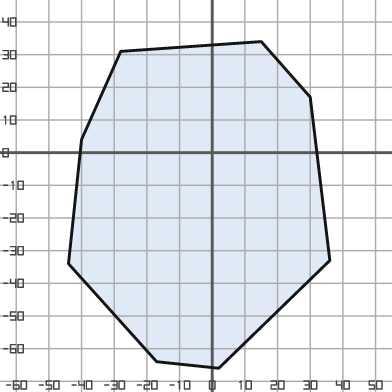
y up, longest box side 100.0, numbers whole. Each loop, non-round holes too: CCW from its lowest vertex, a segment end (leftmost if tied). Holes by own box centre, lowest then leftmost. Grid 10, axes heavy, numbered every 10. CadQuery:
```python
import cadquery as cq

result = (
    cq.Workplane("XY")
    .moveTo(2.0, -66.0)
    .lineTo(36.0, -33.0)
    .lineTo(30.0, 17.0)
    .lineTo(15.0, 34.0)
    .lineTo(-28.0, 31.0)
    .lineTo(-40.0, 4.0)
    .lineTo(-44.0, -34.0)
    .lineTo(-17.0, -64.0)
    .close()
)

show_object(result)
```